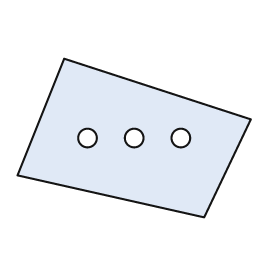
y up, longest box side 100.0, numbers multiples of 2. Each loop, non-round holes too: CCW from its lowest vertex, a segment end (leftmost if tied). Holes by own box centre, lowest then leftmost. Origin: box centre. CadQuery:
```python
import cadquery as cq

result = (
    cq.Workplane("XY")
    .moveTo(30.0, -34.0)
    .lineTo(50.0, 8.0)
    .lineTo(-30.0, 34.0)
    .lineTo(-50.0, -16.0)
    .close()
    .moveTo(-20.0, 0.0)
    .circle(4.0)
    .moveTo(0.0, 0.0)
    .circle(4.0)
    .moveTo(20.0, 0.0)
    .circle(4.0)
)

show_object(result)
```